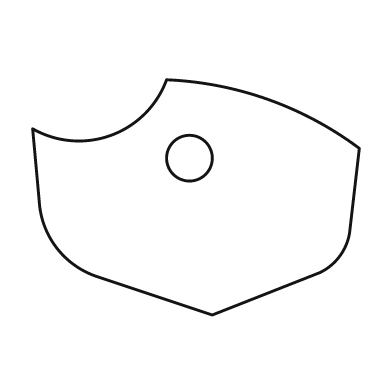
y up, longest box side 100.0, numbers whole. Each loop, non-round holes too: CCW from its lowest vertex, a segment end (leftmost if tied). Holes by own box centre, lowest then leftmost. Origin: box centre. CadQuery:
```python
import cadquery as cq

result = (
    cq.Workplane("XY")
    .moveTo(5.0, -36.0)
    .lineTo(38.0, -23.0)
    .threePointArc((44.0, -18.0), (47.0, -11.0))
    .lineTo(50.0, 15.0)
    .threePointArc((22.0, 30.0), (-9.0, 36.0))
    .threePointArc((-26.0, 19.0), (-50.0, 21.0))
    .lineTo(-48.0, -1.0)
    .threePointArc((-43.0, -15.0), (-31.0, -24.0))
    .close()
    .moveTo(-2.0, 12.0)
    .circle(7.0)
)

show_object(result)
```